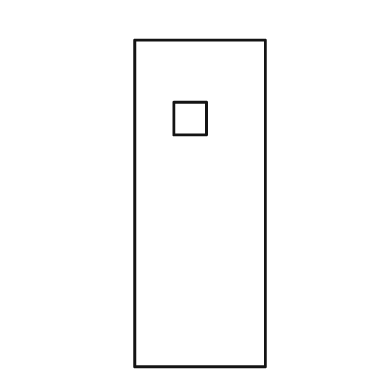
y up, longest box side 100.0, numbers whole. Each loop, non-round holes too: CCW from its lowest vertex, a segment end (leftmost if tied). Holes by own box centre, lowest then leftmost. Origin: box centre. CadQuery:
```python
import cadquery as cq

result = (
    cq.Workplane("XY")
    .moveTo(-20.0, -50.0)
    .lineTo(20.0, -50.0)
    .lineTo(20.0, 50.0)
    .lineTo(-20.0, 50.0)
    .close()
    .moveTo(-8.0, 21.0)
    .lineTo(2.0, 21.0)
    .lineTo(2.0, 31.0)
    .lineTo(-8.0, 31.0)
    .close()
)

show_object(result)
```